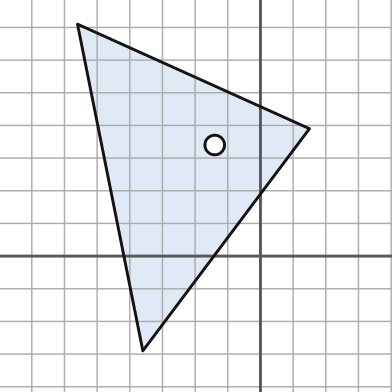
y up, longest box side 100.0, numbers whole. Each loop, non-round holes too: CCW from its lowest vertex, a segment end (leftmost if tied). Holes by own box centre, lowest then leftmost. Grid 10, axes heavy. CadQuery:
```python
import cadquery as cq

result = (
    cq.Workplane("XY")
    .moveTo(-36.0, -29.0)
    .lineTo(15.0, 39.0)
    .lineTo(-56.0, 71.0)
    .close()
    .moveTo(-14.0, 34.0)
    .circle(3.0)
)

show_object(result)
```